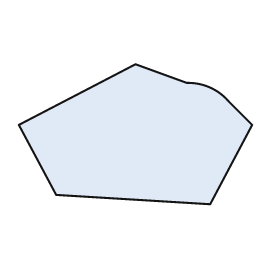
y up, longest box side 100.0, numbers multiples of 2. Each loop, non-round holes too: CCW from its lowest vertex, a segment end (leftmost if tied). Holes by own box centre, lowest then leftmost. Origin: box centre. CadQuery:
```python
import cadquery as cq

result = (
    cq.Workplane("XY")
    .moveTo(32.0, -30.0)
    .lineTo(50.0, 4.0)
    .lineTo(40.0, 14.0)
    .threePointArc((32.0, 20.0), (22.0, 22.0))
    .lineTo(0.0, 30.0)
    .lineTo(-50.0, 4.0)
    .lineTo(-34.0, -26.0)
    .close()
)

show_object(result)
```